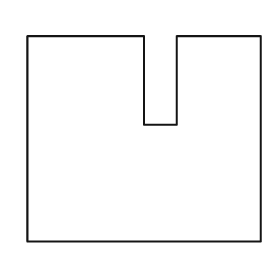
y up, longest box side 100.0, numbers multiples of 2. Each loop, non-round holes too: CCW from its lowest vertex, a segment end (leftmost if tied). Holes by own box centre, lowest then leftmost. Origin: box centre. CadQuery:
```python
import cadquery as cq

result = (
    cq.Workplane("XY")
    .moveTo(-50.0, -44.0)
    .lineTo(50.0, -44.0)
    .lineTo(50.0, 44.0)
    .lineTo(14.0, 44.0)
    .lineTo(14.0, 6.0)
    .lineTo(0.0, 6.0)
    .lineTo(0.0, 44.0)
    .lineTo(-50.0, 44.0)
    .close()
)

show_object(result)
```